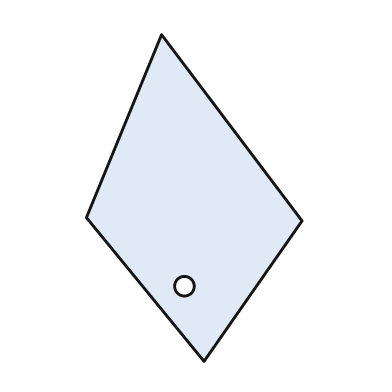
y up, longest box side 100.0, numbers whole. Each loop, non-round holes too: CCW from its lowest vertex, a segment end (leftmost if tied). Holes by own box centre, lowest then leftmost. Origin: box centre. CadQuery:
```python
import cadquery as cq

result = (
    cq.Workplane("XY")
    .moveTo(3.0, -50.0)
    .lineTo(33.0, -7.0)
    .lineTo(-10.0, 50.0)
    .lineTo(-33.0, -6.0)
    .close()
    .moveTo(-3.0, -27.0)
    .circle(3.0)
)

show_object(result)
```